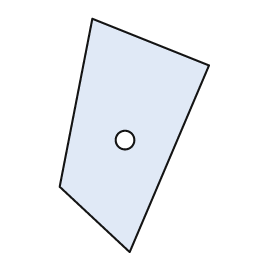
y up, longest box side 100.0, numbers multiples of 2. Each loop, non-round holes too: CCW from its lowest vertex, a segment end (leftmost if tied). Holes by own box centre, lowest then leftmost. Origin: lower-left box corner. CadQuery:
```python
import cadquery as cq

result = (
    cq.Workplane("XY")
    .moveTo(30.0, 0.0)
    .lineTo(64.0, 80.0)
    .lineTo(14.0, 100.0)
    .lineTo(0.0, 28.0)
    .close()
    .moveTo(28.0, 48.0)
    .circle(4.0)
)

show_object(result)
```